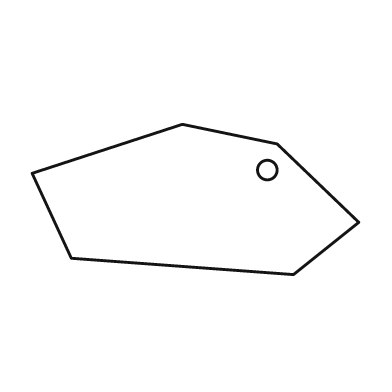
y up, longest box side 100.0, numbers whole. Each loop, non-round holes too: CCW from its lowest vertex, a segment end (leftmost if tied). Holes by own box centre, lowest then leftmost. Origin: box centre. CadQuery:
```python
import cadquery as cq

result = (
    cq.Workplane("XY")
    .moveTo(30.0, -23.0)
    .lineTo(50.0, -7.0)
    .lineTo(25.0, 17.0)
    .lineTo(-4.0, 23.0)
    .lineTo(-50.0, 8.0)
    .lineTo(-38.0, -18.0)
    .close()
    .moveTo(22.0, 9.0)
    .circle(3.0)
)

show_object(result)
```